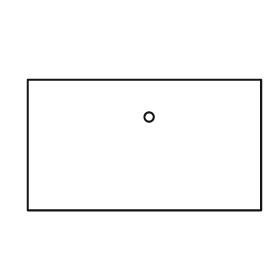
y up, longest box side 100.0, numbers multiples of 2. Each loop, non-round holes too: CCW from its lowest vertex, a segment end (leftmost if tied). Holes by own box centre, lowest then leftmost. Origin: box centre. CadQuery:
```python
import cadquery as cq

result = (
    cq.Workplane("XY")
    .moveTo(-50.0, -28.0)
    .lineTo(50.0, -28.0)
    .lineTo(50.0, 28.0)
    .lineTo(-50.0, 28.0)
    .close()
    .moveTo(2.0, 12.0)
    .circle(2.0)
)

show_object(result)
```